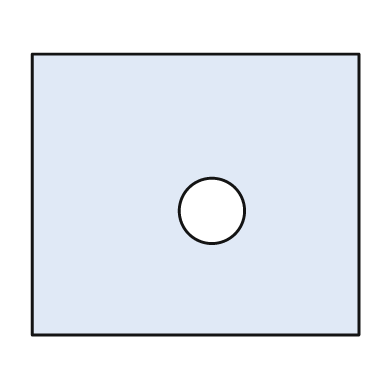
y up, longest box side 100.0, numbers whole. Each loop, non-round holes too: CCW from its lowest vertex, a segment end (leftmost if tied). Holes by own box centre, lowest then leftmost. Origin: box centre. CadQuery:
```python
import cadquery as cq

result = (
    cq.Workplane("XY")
    .moveTo(-50.0, -43.0)
    .lineTo(50.0, -43.0)
    .lineTo(50.0, 43.0)
    .lineTo(-50.0, 43.0)
    .close()
    .moveTo(5.0, -5.0)
    .circle(10.0)
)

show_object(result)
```